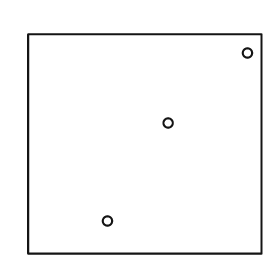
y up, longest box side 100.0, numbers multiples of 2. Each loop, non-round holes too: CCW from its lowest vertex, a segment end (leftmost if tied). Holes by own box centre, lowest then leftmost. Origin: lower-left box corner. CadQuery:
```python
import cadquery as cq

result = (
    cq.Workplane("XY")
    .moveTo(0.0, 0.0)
    .lineTo(100.0, 0.0)
    .lineTo(100.0, 94.0)
    .lineTo(0.0, 94.0)
    .close()
    .moveTo(34.0, 14.0)
    .circle(2.0)
    .moveTo(60.0, 56.0)
    .circle(2.0)
    .moveTo(94.0, 86.0)
    .circle(2.0)
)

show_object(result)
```